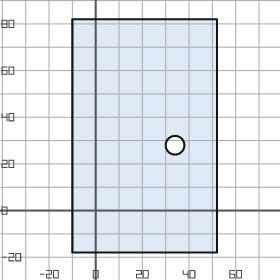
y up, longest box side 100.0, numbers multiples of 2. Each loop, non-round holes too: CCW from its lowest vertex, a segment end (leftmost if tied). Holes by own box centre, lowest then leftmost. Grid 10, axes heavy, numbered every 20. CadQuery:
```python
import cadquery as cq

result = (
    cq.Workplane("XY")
    .moveTo(-10.0, -18.0)
    .lineTo(52.0, -18.0)
    .lineTo(52.0, 82.0)
    .lineTo(-10.0, 82.0)
    .close()
    .moveTo(34.0, 28.0)
    .circle(4.0)
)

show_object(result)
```